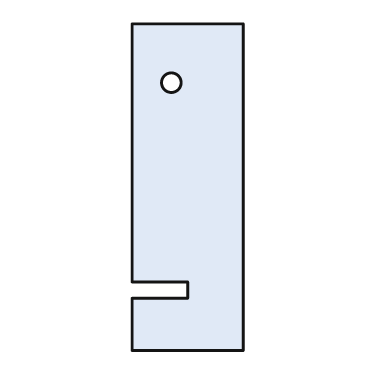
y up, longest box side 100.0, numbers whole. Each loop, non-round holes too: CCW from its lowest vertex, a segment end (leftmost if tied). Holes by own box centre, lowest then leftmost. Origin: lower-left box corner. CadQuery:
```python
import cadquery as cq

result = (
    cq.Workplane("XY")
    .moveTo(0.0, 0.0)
    .lineTo(34.0, 0.0)
    .lineTo(34.0, 100.0)
    .lineTo(0.0, 100.0)
    .lineTo(0.0, 21.0)
    .lineTo(17.0, 21.0)
    .lineTo(17.0, 16.0)
    .lineTo(0.0, 16.0)
    .close()
    .moveTo(12.0, 82.0)
    .circle(3.0)
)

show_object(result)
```